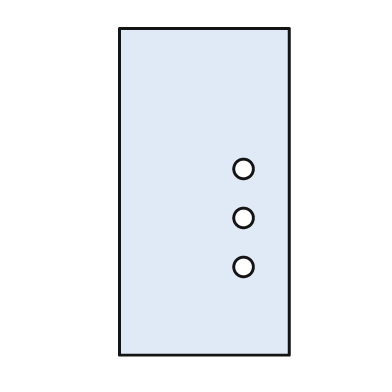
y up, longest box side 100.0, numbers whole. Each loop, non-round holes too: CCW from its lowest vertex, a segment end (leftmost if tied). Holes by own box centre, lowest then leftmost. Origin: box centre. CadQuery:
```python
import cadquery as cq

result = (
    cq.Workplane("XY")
    .moveTo(-26.0, -50.0)
    .lineTo(26.0, -50.0)
    .lineTo(26.0, 50.0)
    .lineTo(-26.0, 50.0)
    .close()
    .moveTo(12.0, -23.0)
    .circle(3.0)
    .moveTo(12.0, -8.0)
    .circle(3.0)
    .moveTo(12.0, 7.0)
    .circle(3.0)
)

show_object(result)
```